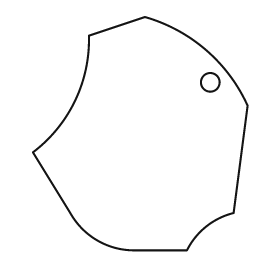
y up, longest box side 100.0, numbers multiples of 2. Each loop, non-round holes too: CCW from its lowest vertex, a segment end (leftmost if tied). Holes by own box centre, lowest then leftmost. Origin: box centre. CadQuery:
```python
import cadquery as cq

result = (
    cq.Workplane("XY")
    .moveTo(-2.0, -50.0)
    .lineTo(20.0, -50.0)
    .threePointArc((28.0, -40.0), (40.0, -34.0))
    .lineTo(46.0, 12.0)
    .threePointArc((28.0, 36.0), (2.0, 50.0))
    .lineTo(-22.0, 42.0)
    .threePointArc((-28.0, 14.0), (-46.0, -8.0))
    .lineTo(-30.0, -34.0)
    .threePointArc((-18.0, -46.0), (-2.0, -50.0))
    .close()
    .moveTo(30.0, 22.0)
    .circle(4.0)
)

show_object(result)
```